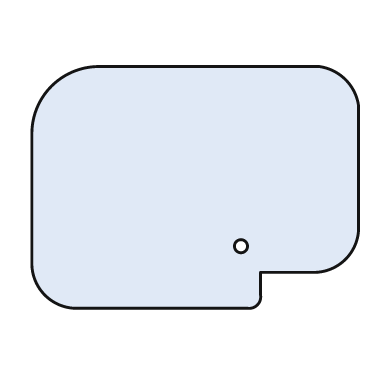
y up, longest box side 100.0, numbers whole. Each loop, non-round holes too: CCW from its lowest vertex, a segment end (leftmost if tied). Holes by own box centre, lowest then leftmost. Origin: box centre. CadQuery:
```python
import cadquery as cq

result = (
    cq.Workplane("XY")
    .moveTo(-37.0, -37.0)
    .lineTo(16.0, -37.0)
    .threePointArc((19.0, -36.0), (20.0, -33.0))
    .lineTo(20.0, -26.0)
    .lineTo(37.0, -26.0)
    .threePointArc((46.0, -22.0), (50.0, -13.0))
    .lineTo(50.0, 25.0)
    .threePointArc((46.0, 33.0), (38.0, 37.0))
    .lineTo(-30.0, 37.0)
    .threePointArc((-44.0, 31.0), (-50.0, 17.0))
    .lineTo(-50.0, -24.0)
    .threePointArc((-46.0, -33.0), (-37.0, -37.0))
    .close()
    .moveTo(14.0, -18.0)
    .circle(2.0)
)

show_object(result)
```